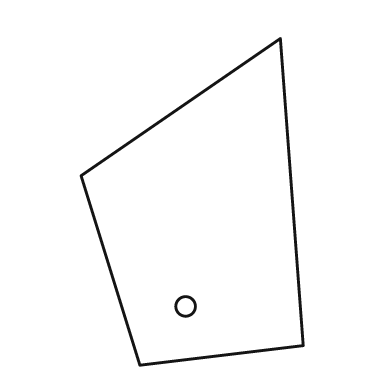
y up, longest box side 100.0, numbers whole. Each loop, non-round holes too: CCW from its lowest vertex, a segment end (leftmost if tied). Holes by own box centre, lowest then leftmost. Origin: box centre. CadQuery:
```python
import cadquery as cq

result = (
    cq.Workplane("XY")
    .moveTo(-16.0, -50.0)
    .lineTo(34.0, -44.0)
    .lineTo(27.0, 50.0)
    .lineTo(-34.0, 8.0)
    .close()
    .moveTo(-2.0, -32.0)
    .circle(3.0)
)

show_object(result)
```